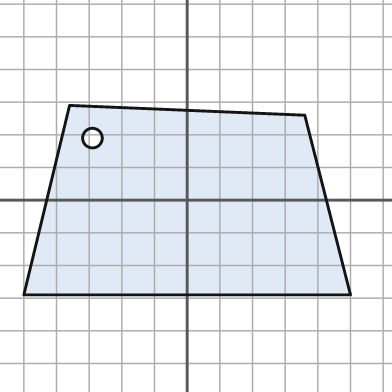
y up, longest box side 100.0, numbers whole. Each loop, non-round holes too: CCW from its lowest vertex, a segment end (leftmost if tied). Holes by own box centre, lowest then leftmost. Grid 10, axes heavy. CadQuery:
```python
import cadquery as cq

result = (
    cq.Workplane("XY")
    .moveTo(-50.0, -29.0)
    .lineTo(50.0, -29.0)
    .lineTo(36.0, 26.0)
    .lineTo(-36.0, 29.0)
    .close()
    .moveTo(-29.0, 19.0)
    .circle(3.0)
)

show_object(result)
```